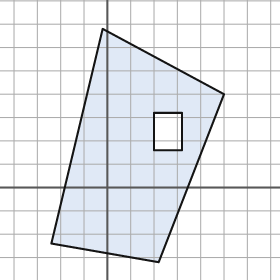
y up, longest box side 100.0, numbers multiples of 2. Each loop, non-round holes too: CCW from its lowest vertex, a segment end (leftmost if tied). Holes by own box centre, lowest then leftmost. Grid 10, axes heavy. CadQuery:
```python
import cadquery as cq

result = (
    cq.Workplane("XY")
    .moveTo(22.0, -32.0)
    .lineTo(50.0, 40.0)
    .lineTo(-2.0, 68.0)
    .lineTo(-24.0, -24.0)
    .close()
    .moveTo(20.0, 16.0)
    .lineTo(32.0, 16.0)
    .lineTo(32.0, 32.0)
    .lineTo(20.0, 32.0)
    .close()
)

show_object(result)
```